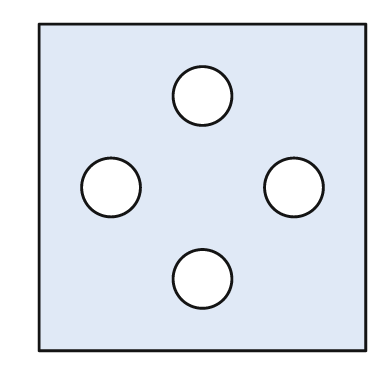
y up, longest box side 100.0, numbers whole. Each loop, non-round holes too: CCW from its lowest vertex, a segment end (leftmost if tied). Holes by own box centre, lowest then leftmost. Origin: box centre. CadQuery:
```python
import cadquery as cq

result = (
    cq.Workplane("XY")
    .moveTo(-50.0, -50.0)
    .lineTo(50.0, -50.0)
    .lineTo(50.0, 50.0)
    .lineTo(-50.0, 50.0)
    .close()
    .moveTo(0.0, -28.0)
    .circle(9.0)
    .moveTo(-28.0, 0.0)
    .circle(9.0)
    .moveTo(28.0, 0.0)
    .circle(9.0)
    .moveTo(0.0, 28.0)
    .circle(9.0)
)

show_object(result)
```